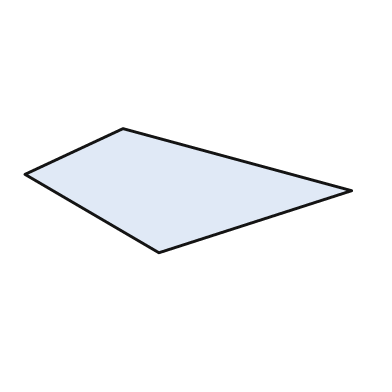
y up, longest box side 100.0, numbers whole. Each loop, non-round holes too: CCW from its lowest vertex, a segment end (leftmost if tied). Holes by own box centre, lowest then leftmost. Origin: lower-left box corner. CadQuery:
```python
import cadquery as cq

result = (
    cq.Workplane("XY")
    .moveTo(41.0, 0.0)
    .lineTo(100.0, 19.0)
    .lineTo(30.0, 38.0)
    .lineTo(0.0, 24.0)
    .close()
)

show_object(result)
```